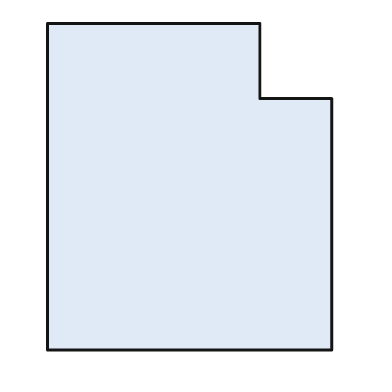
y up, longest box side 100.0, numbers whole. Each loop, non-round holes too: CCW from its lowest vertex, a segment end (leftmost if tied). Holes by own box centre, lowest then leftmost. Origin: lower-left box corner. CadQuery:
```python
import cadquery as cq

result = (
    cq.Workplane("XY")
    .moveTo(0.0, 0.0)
    .lineTo(87.0, 0.0)
    .lineTo(87.0, 77.0)
    .lineTo(65.0, 77.0)
    .lineTo(65.0, 100.0)
    .lineTo(0.0, 100.0)
    .close()
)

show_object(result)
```